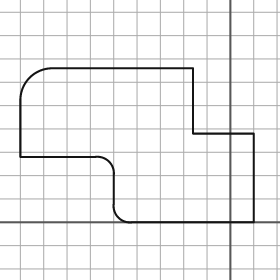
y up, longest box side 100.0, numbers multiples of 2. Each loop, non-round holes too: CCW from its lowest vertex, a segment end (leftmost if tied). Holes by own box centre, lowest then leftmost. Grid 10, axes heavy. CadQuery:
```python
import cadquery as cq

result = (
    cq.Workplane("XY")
    .moveTo(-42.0, 0.0)
    .lineTo(10.0, 0.0)
    .lineTo(10.0, 38.0)
    .lineTo(-16.0, 38.0)
    .lineTo(-16.0, 66.0)
    .lineTo(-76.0, 66.0)
    .threePointArc((-86.0, 62.0), (-90.0, 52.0))
    .lineTo(-90.0, 28.0)
    .lineTo(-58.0, 28.0)
    .threePointArc((-52.0, 26.0), (-50.0, 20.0))
    .lineTo(-50.0, 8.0)
    .threePointArc((-48.0, 2.0), (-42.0, 0.0))
    .close()
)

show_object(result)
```